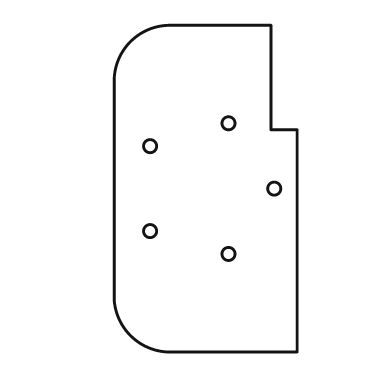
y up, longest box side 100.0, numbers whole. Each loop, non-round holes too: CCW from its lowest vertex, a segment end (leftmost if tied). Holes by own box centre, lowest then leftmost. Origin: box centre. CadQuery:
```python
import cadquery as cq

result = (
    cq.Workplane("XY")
    .moveTo(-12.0, -50.0)
    .lineTo(28.0, -50.0)
    .lineTo(28.0, 18.0)
    .lineTo(20.0, 18.0)
    .lineTo(20.0, 50.0)
    .lineTo(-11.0, 50.0)
    .threePointArc((-23.0, 45.0), (-28.0, 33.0))
    .lineTo(-28.0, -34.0)
    .threePointArc((-23.0, -45.0), (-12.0, -50.0))
    .close()
    .moveTo(7.0, -20.0)
    .circle(2.0)
    .moveTo(-17.0, -13.0)
    .circle(2.0)
    .moveTo(21.0, 0.0)
    .circle(2.0)
    .moveTo(-17.0, 13.0)
    .circle(2.0)
    .moveTo(7.0, 20.0)
    .circle(2.0)
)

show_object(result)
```